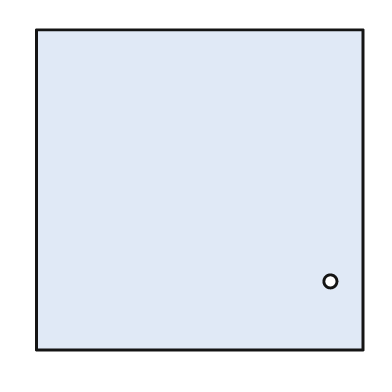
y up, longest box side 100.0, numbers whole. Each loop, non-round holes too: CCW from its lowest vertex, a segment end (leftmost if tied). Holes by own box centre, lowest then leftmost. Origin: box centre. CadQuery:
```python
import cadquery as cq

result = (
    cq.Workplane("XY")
    .moveTo(-50.0, -49.0)
    .lineTo(50.0, -49.0)
    .lineTo(50.0, 49.0)
    .lineTo(-50.0, 49.0)
    .close()
    .moveTo(40.0, -28.0)
    .circle(2.0)
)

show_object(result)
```